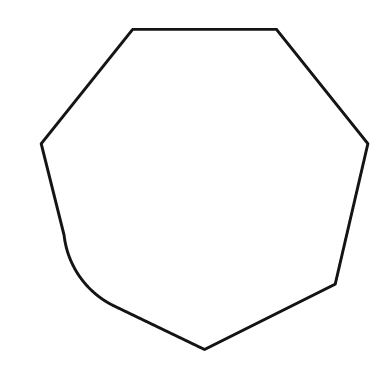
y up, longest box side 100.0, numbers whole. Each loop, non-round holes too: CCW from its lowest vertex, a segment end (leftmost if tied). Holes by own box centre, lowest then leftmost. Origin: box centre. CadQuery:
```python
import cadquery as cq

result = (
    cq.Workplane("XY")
    .moveTo(0.0, -49.0)
    .lineTo(40.0, -29.0)
    .lineTo(50.0, 14.0)
    .lineTo(22.0, 49.0)
    .lineTo(-22.0, 49.0)
    .lineTo(-50.0, 14.0)
    .lineTo(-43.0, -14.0)
    .threePointArc((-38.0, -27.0), (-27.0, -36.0))
    .close()
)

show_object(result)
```